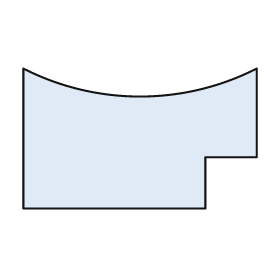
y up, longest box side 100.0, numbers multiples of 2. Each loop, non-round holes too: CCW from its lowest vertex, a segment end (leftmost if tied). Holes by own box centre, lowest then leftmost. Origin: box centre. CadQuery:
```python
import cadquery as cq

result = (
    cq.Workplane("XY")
    .moveTo(-50.0, -30.0)
    .lineTo(28.0, -30.0)
    .lineTo(28.0, -8.0)
    .lineTo(50.0, -8.0)
    .lineTo(50.0, 30.0)
    .threePointArc((0.0, 18.0), (-50.0, 30.0))
    .close()
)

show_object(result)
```